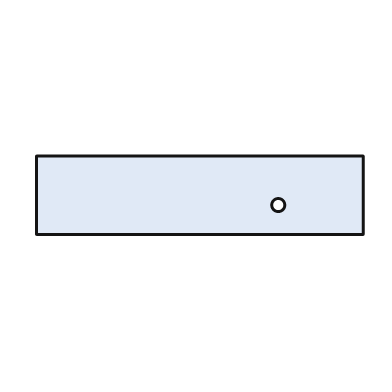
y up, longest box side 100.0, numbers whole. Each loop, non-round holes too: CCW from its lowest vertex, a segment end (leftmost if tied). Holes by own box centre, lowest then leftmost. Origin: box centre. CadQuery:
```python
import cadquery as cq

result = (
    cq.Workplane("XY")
    .moveTo(-50.0, -12.0)
    .lineTo(50.0, -12.0)
    .lineTo(50.0, 12.0)
    .lineTo(-50.0, 12.0)
    .close()
    .moveTo(24.0, -3.0)
    .circle(2.0)
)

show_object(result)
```